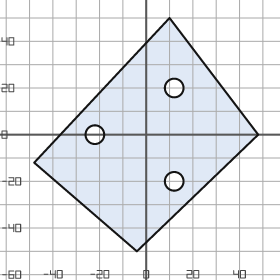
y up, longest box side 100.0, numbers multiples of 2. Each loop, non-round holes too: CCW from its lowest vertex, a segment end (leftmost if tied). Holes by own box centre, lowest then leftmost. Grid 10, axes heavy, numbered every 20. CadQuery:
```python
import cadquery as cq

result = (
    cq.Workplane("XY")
    .moveTo(-4.0, -50.0)
    .lineTo(48.0, 0.0)
    .lineTo(10.0, 50.0)
    .lineTo(-48.0, -12.0)
    .close()
    .moveTo(12.0, -20.0)
    .circle(4.0)
    .moveTo(-22.0, 0.0)
    .circle(4.0)
    .moveTo(12.0, 20.0)
    .circle(4.0)
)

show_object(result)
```